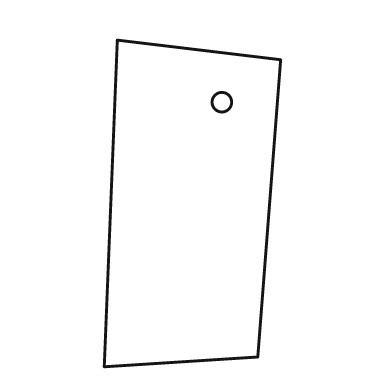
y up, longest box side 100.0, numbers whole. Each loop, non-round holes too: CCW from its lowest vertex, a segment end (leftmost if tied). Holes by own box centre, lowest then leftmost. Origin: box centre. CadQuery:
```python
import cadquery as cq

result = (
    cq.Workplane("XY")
    .moveTo(-27.0, -50.0)
    .lineTo(20.0, -47.0)
    .lineTo(27.0, 44.0)
    .lineTo(-23.0, 50.0)
    .close()
    .moveTo(9.0, 31.0)
    .circle(3.0)
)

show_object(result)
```